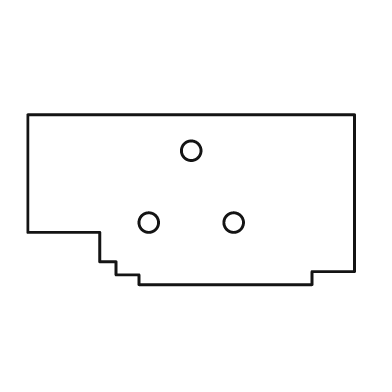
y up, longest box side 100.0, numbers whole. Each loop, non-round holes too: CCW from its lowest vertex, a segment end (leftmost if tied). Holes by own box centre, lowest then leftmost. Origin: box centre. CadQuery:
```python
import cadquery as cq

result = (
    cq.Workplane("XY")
    .moveTo(-16.0, -26.0)
    .lineTo(37.0, -26.0)
    .lineTo(37.0, -22.0)
    .lineTo(50.0, -22.0)
    .lineTo(50.0, 26.0)
    .lineTo(-50.0, 26.0)
    .lineTo(-50.0, -10.0)
    .lineTo(-28.0, -10.0)
    .lineTo(-28.0, -19.0)
    .lineTo(-23.0, -19.0)
    .lineTo(-23.0, -23.0)
    .lineTo(-16.0, -23.0)
    .close()
    .moveTo(-13.0, -7.0)
    .circle(3.0)
    .moveTo(13.0, -7.0)
    .circle(3.0)
    .moveTo(0.0, 15.0)
    .circle(3.0)
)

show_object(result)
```